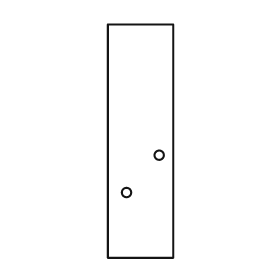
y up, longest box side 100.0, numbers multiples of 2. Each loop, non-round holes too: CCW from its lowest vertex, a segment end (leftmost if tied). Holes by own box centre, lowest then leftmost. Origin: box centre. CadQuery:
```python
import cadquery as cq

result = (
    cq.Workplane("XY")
    .moveTo(-14.0, -50.0)
    .lineTo(14.0, -50.0)
    .lineTo(14.0, 50.0)
    .lineTo(-14.0, 50.0)
    .close()
    .moveTo(-6.0, -22.0)
    .circle(2.0)
    .moveTo(8.0, -6.0)
    .circle(2.0)
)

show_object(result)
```